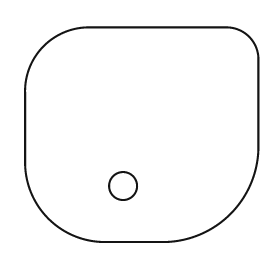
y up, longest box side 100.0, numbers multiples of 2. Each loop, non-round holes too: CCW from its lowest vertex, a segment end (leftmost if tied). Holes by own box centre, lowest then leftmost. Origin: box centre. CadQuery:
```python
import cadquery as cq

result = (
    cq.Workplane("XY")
    .moveTo(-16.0, -46.0)
    .lineTo(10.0, -46.0)
    .threePointArc((38.0, -34.0), (50.0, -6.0))
    .lineTo(50.0, 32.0)
    .threePointArc((46.0, 42.0), (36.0, 46.0))
    .lineTo(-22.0, 46.0)
    .threePointArc((-42.0, 38.0), (-50.0, 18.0))
    .lineTo(-50.0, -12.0)
    .threePointArc((-40.0, -36.0), (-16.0, -46.0))
    .close()
    .moveTo(-8.0, -22.0)
    .circle(6.0)
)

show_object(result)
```